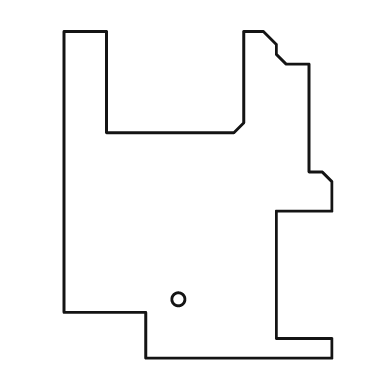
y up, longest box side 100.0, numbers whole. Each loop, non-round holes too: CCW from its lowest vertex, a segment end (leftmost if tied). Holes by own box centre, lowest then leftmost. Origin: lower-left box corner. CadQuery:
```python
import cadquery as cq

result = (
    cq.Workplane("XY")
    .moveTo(25.0, 0.0)
    .lineTo(82.0, 0.0)
    .lineTo(82.0, 6.0)
    .lineTo(65.0, 6.0)
    .lineTo(65.0, 45.0)
    .lineTo(82.0, 45.0)
    .lineTo(82.0, 54.0)
    .lineTo(79.0, 57.0)
    .lineTo(75.0, 57.0)
    .lineTo(75.0, 90.0)
    .lineTo(68.0, 90.0)
    .lineTo(65.0, 93.0)
    .lineTo(65.0, 96.0)
    .lineTo(61.0, 100.0)
    .lineTo(55.0, 100.0)
    .lineTo(55.0, 72.0)
    .lineTo(52.0, 69.0)
    .lineTo(13.0, 69.0)
    .lineTo(13.0, 100.0)
    .lineTo(0.0, 100.0)
    .lineTo(0.0, 14.0)
    .lineTo(25.0, 14.0)
    .close()
    .moveTo(35.0, 18.0)
    .circle(2.0)
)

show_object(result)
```